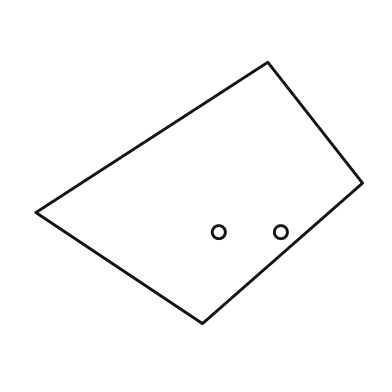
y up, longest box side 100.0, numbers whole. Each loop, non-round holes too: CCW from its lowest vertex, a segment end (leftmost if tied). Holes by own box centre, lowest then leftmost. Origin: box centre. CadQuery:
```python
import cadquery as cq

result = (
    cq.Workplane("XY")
    .moveTo(1.0, -40.0)
    .lineTo(50.0, 3.0)
    .lineTo(21.0, 40.0)
    .lineTo(-50.0, -6.0)
    .close()
    .moveTo(6.0, -12.0)
    .circle(2.0)
    .moveTo(25.0, -12.0)
    .circle(2.0)
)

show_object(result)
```